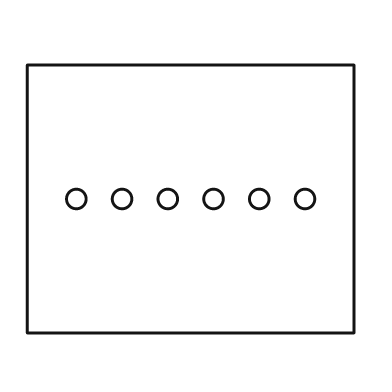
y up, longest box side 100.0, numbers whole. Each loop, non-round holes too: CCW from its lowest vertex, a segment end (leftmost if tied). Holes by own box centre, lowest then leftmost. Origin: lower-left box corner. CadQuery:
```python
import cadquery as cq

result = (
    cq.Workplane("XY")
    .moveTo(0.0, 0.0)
    .lineTo(100.0, 0.0)
    .lineTo(100.0, 82.0)
    .lineTo(0.0, 82.0)
    .close()
    .moveTo(15.0, 41.0)
    .circle(3.0)
    .moveTo(29.0, 41.0)
    .circle(3.0)
    .moveTo(43.0, 41.0)
    .circle(3.0)
    .moveTo(57.0, 41.0)
    .circle(3.0)
    .moveTo(71.0, 41.0)
    .circle(3.0)
    .moveTo(85.0, 41.0)
    .circle(3.0)
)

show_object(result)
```